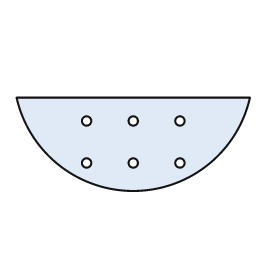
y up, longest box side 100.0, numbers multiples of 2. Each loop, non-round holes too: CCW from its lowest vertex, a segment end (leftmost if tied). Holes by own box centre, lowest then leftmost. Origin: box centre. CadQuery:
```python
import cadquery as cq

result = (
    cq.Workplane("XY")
    .moveTo(-50.0, 20.0)
    .threePointArc((0.0, -20.0), (50.0, 20.0))
    .close()
    .moveTo(-20.0, -8.0)
    .circle(2.0)
    .moveTo(0.0, -8.0)
    .circle(2.0)
    .moveTo(20.0, -8.0)
    .circle(2.0)
    .moveTo(-20.0, 10.0)
    .circle(2.0)
    .moveTo(0.0, 10.0)
    .circle(2.0)
    .moveTo(20.0, 10.0)
    .circle(2.0)
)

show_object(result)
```